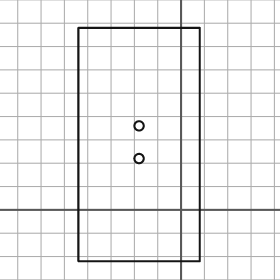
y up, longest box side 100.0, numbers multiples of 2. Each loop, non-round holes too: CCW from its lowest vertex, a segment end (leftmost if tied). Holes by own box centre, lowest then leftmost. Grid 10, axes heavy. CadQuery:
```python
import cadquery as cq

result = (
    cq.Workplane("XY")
    .moveTo(-44.0, -22.0)
    .lineTo(8.0, -22.0)
    .lineTo(8.0, 78.0)
    .lineTo(-44.0, 78.0)
    .close()
    .moveTo(-18.0, 22.0)
    .circle(2.0)
    .moveTo(-18.0, 36.0)
    .circle(2.0)
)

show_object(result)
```